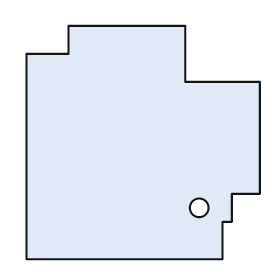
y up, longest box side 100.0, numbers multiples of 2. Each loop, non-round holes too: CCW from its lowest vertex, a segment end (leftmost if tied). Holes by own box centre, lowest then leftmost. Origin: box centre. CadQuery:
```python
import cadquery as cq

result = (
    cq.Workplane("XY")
    .moveTo(-50.0, -50.0)
    .lineTo(34.0, -50.0)
    .lineTo(34.0, -34.0)
    .lineTo(38.0, -34.0)
    .lineTo(38.0, -22.0)
    .lineTo(50.0, -22.0)
    .lineTo(50.0, 26.0)
    .lineTo(18.0, 26.0)
    .lineTo(18.0, 50.0)
    .lineTo(-32.0, 50.0)
    .lineTo(-32.0, 38.0)
    .lineTo(-50.0, 38.0)
    .close()
    .moveTo(24.0, -28.0)
    .circle(4.0)
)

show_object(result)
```